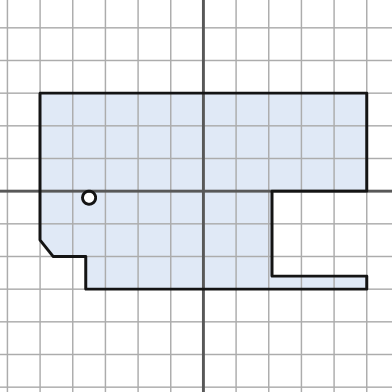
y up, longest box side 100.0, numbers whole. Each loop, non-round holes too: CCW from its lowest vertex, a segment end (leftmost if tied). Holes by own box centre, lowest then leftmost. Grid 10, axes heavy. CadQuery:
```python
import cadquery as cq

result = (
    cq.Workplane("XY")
    .moveTo(-36.0, -30.0)
    .lineTo(50.0, -30.0)
    .lineTo(50.0, -26.0)
    .lineTo(21.0, -26.0)
    .lineTo(21.0, 0.0)
    .lineTo(50.0, 0.0)
    .lineTo(50.0, 30.0)
    .lineTo(-50.0, 30.0)
    .lineTo(-50.0, -15.0)
    .lineTo(-46.0, -20.0)
    .lineTo(-36.0, -20.0)
    .close()
    .moveTo(-35.0, -2.0)
    .circle(2.0)
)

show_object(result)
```